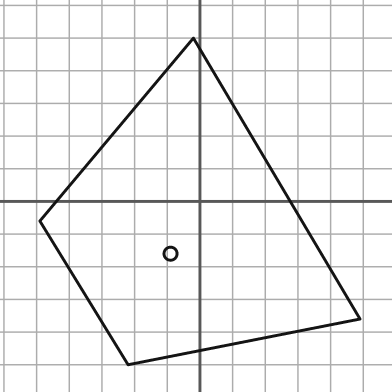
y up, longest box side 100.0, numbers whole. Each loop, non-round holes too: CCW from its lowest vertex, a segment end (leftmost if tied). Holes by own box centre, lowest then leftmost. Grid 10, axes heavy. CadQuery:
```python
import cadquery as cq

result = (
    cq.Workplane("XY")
    .moveTo(-22.0, -50.0)
    .lineTo(49.0, -36.0)
    .lineTo(-2.0, 50.0)
    .lineTo(-49.0, -6.0)
    .close()
    .moveTo(-9.0, -16.0)
    .circle(2.0)
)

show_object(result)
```